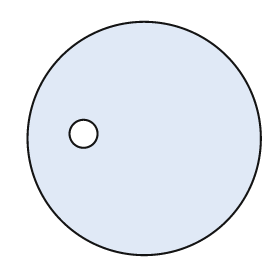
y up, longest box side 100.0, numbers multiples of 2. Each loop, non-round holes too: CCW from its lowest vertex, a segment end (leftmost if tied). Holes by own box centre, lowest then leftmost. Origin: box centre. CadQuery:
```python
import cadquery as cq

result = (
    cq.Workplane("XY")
    .moveTo(0.0, 0.0)
    .circle(50.0)
    .moveTo(-26.0, 2.0)
    .circle(6.0)
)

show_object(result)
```